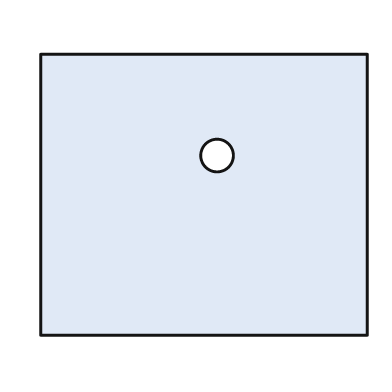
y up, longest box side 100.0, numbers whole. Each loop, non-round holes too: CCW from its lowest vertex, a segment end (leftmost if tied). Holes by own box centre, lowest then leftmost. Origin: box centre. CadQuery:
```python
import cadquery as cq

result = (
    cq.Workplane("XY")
    .moveTo(-50.0, -43.0)
    .lineTo(50.0, -43.0)
    .lineTo(50.0, 43.0)
    .lineTo(-50.0, 43.0)
    .close()
    .moveTo(4.0, 12.0)
    .circle(5.0)
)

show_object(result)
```